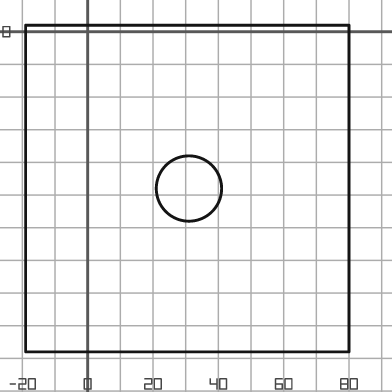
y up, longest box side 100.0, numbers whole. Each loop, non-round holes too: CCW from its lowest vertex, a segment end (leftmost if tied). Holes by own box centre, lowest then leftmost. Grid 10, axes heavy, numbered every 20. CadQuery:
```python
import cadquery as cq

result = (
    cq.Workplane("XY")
    .moveTo(-19.0, -98.0)
    .lineTo(80.0, -98.0)
    .lineTo(80.0, 2.0)
    .lineTo(-19.0, 2.0)
    .close()
    .moveTo(31.0, -48.0)
    .circle(10.0)
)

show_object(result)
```